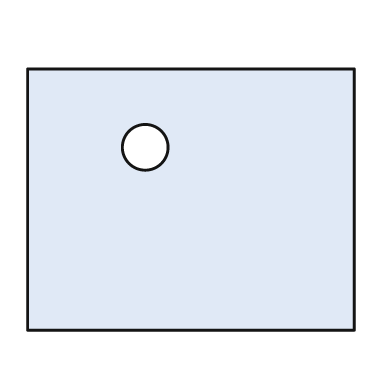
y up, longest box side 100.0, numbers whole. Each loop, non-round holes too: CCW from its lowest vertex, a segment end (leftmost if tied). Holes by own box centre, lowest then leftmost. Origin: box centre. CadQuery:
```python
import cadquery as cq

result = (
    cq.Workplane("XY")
    .moveTo(-50.0, -40.0)
    .lineTo(50.0, -40.0)
    .lineTo(50.0, 40.0)
    .lineTo(-50.0, 40.0)
    .close()
    .moveTo(-14.0, 16.0)
    .circle(7.0)
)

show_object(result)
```